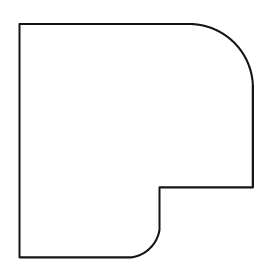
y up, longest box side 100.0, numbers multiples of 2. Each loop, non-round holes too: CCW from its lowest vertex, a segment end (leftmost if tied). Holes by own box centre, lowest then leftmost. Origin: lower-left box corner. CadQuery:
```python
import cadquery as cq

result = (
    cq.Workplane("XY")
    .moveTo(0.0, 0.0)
    .lineTo(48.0, 0.0)
    .threePointArc((56.0, 4.0), (60.0, 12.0))
    .lineTo(60.0, 30.0)
    .lineTo(100.0, 30.0)
    .lineTo(100.0, 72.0)
    .threePointArc((92.0, 92.0), (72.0, 100.0))
    .lineTo(0.0, 100.0)
    .close()
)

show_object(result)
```